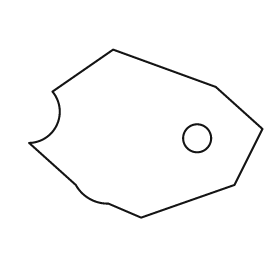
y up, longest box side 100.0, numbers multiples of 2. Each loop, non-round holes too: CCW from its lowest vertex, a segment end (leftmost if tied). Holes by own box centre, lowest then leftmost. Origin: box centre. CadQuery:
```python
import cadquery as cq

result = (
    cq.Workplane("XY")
    .moveTo(-2.0, -36.0)
    .lineTo(38.0, -22.0)
    .lineTo(50.0, 2.0)
    .lineTo(30.0, 20.0)
    .lineTo(-14.0, 36.0)
    .lineTo(-40.0, 18.0)
    .threePointArc((-38.0, 4.0), (-50.0, -4.0))
    .lineTo(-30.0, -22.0)
    .threePointArc((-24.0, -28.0), (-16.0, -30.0))
    .close()
    .moveTo(22.0, -2.0)
    .circle(6.0)
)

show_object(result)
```